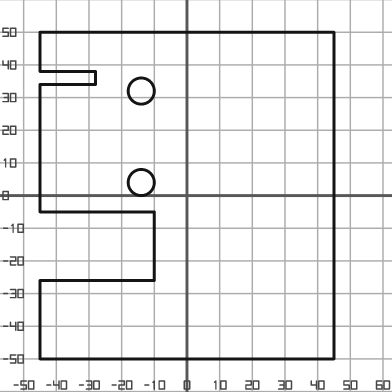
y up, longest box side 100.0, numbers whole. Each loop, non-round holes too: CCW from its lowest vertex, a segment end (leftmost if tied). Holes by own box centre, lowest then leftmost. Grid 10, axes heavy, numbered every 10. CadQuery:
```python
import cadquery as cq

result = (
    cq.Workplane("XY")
    .moveTo(-45.0, -50.0)
    .lineTo(45.0, -50.0)
    .lineTo(45.0, 50.0)
    .lineTo(-45.0, 50.0)
    .lineTo(-45.0, 38.0)
    .lineTo(-28.0, 38.0)
    .lineTo(-28.0, 34.0)
    .lineTo(-45.0, 34.0)
    .lineTo(-45.0, -5.0)
    .lineTo(-10.0, -5.0)
    .lineTo(-10.0, -26.0)
    .lineTo(-45.0, -26.0)
    .close()
    .moveTo(-14.0, 4.0)
    .circle(4.0)
    .moveTo(-14.0, 32.0)
    .circle(4.0)
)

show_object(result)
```